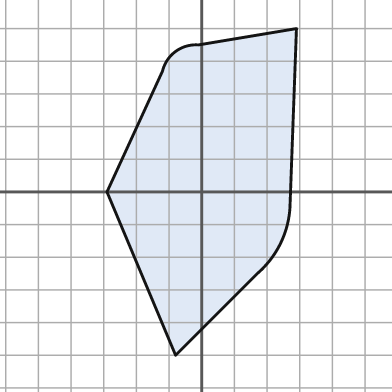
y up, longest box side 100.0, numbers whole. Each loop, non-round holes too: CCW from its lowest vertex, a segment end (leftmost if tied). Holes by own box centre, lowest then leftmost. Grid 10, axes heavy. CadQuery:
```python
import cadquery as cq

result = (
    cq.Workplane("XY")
    .moveTo(-8.0, -50.0)
    .lineTo(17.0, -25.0)
    .threePointArc((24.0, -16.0), (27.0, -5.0))
    .lineTo(29.0, 50.0)
    .lineTo(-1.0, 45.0)
    .threePointArc((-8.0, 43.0), (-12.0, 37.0))
    .lineTo(-29.0, 0.0)
    .close()
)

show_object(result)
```